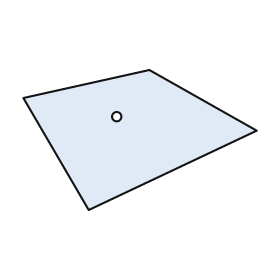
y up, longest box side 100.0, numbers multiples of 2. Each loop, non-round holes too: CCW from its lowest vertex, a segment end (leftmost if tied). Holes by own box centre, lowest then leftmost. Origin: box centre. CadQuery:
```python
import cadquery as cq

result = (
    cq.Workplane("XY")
    .moveTo(-22.0, -30.0)
    .lineTo(50.0, 4.0)
    .lineTo(4.0, 30.0)
    .lineTo(-50.0, 18.0)
    .close()
    .moveTo(-10.0, 10.0)
    .circle(2.0)
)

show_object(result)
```